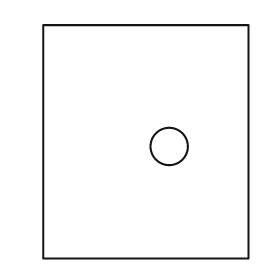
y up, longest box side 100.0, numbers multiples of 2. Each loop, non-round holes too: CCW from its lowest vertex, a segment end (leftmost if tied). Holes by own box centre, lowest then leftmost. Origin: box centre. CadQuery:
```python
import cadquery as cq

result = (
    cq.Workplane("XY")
    .moveTo(-44.0, -50.0)
    .lineTo(44.0, -50.0)
    .lineTo(44.0, 50.0)
    .lineTo(-44.0, 50.0)
    .close()
    .moveTo(10.0, -2.0)
    .circle(8.0)
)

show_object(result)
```